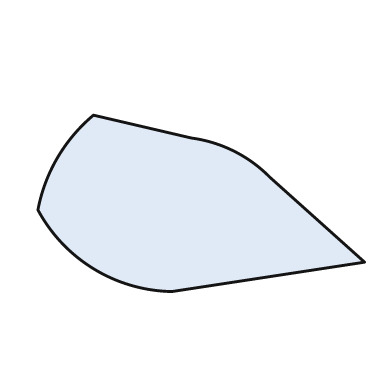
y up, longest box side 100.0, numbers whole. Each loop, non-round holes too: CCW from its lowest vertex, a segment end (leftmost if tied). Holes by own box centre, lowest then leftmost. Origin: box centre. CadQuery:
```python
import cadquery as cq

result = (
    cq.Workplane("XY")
    .moveTo(-9.0, -27.0)
    .lineTo(50.0, -18.0)
    .lineTo(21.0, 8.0)
    .threePointArc((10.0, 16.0), (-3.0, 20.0))
    .lineTo(-33.0, 27.0)
    .threePointArc((-44.0, 14.0), (-50.0, -2.0))
    .threePointArc((-33.0, -20.0), (-9.0, -27.0))
    .close()
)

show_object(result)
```